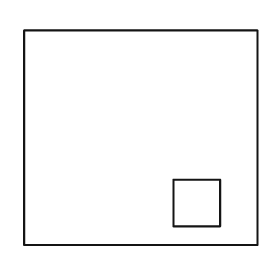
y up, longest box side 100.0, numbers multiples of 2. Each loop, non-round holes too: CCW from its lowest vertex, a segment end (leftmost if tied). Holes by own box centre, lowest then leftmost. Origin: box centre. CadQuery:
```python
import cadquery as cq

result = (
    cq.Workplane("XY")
    .moveTo(-50.0, -46.0)
    .lineTo(50.0, -46.0)
    .lineTo(50.0, 46.0)
    .lineTo(-50.0, 46.0)
    .close()
    .moveTo(14.0, -38.0)
    .lineTo(34.0, -38.0)
    .lineTo(34.0, -18.0)
    .lineTo(14.0, -18.0)
    .close()
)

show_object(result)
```